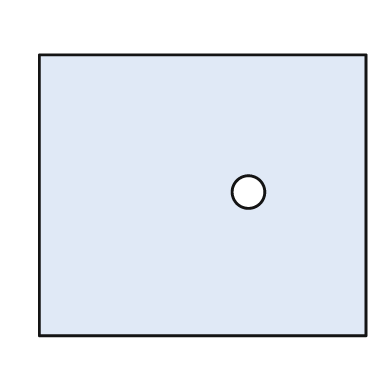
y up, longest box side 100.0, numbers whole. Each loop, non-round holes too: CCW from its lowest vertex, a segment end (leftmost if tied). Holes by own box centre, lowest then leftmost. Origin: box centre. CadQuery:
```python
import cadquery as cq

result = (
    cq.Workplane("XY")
    .moveTo(-50.0, -43.0)
    .lineTo(50.0, -43.0)
    .lineTo(50.0, 43.0)
    .lineTo(-50.0, 43.0)
    .close()
    .moveTo(14.0, 1.0)
    .circle(5.0)
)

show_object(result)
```